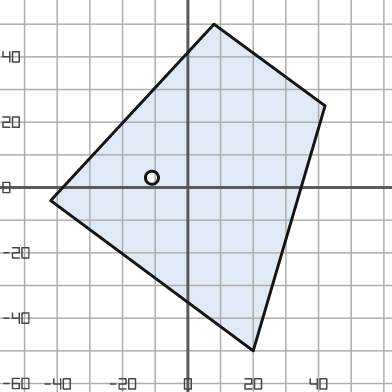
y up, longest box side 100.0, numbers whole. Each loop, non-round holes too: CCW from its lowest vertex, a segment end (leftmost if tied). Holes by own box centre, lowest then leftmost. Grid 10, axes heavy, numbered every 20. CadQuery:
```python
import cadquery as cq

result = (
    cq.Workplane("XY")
    .moveTo(20.0, -50.0)
    .lineTo(42.0, 25.0)
    .lineTo(8.0, 50.0)
    .lineTo(-42.0, -4.0)
    .close()
    .moveTo(-11.0, 3.0)
    .circle(2.0)
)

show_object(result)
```